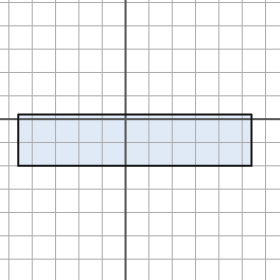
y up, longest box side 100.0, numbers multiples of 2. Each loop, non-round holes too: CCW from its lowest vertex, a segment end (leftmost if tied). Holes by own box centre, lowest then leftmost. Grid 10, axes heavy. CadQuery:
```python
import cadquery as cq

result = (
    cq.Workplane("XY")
    .moveTo(-46.0, -20.0)
    .lineTo(54.0, -20.0)
    .lineTo(54.0, 2.0)
    .lineTo(-46.0, 2.0)
    .close()
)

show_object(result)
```